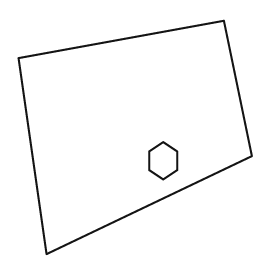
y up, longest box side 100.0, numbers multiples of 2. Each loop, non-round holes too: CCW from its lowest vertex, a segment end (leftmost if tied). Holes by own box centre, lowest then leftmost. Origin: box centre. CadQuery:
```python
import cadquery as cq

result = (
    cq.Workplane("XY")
    .moveTo(-38.0, -50.0)
    .lineTo(50.0, -8.0)
    .lineTo(38.0, 50.0)
    .lineTo(-50.0, 34.0)
    .close()
    .moveTo(12.0, -18.0)
    .lineTo(18.0, -14.0)
    .lineTo(18.0, -6.0)
    .lineTo(12.0, -2.0)
    .lineTo(6.0, -6.0)
    .lineTo(6.0, -14.0)
    .close()
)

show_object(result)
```